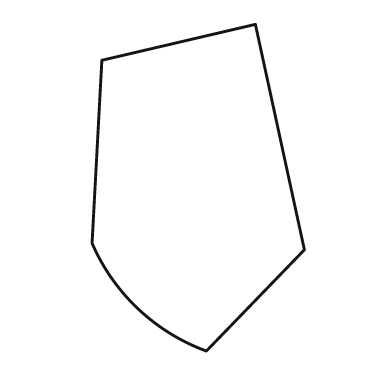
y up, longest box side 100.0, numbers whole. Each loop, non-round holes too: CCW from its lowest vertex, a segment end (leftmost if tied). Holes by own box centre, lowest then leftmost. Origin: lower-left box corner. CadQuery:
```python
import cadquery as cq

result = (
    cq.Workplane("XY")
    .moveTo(35.0, 0.0)
    .lineTo(65.0, 31.0)
    .lineTo(50.0, 100.0)
    .lineTo(3.0, 89.0)
    .lineTo(0.0, 33.0)
    .threePointArc((14.0, 13.0), (35.0, 0.0))
    .close()
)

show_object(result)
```